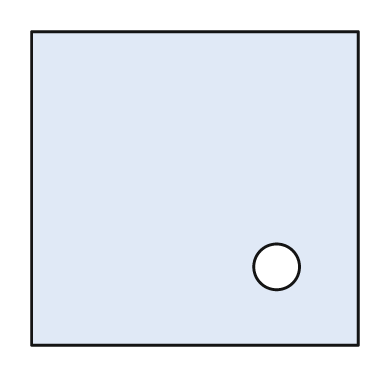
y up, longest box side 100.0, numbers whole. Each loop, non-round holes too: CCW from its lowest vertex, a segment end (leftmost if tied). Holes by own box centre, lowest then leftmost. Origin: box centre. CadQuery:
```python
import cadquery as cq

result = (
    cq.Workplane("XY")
    .moveTo(-50.0, -48.0)
    .lineTo(50.0, -48.0)
    .lineTo(50.0, 48.0)
    .lineTo(-50.0, 48.0)
    .close()
    .moveTo(25.0, -24.0)
    .circle(7.0)
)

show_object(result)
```